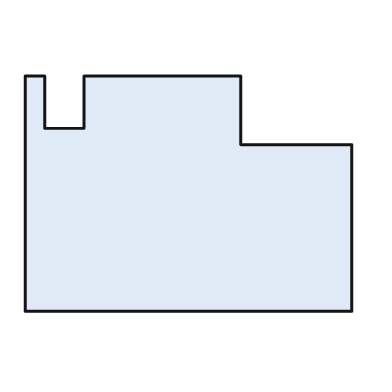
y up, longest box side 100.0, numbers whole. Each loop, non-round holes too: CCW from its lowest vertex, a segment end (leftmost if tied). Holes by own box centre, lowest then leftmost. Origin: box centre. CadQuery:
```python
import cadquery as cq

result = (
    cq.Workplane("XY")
    .moveTo(-50.0, -36.0)
    .lineTo(50.0, -36.0)
    .lineTo(50.0, 15.0)
    .lineTo(16.0, 15.0)
    .lineTo(16.0, 36.0)
    .lineTo(-32.0, 36.0)
    .lineTo(-32.0, 20.0)
    .lineTo(-44.0, 20.0)
    .lineTo(-44.0, 36.0)
    .lineTo(-50.0, 36.0)
    .close()
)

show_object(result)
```